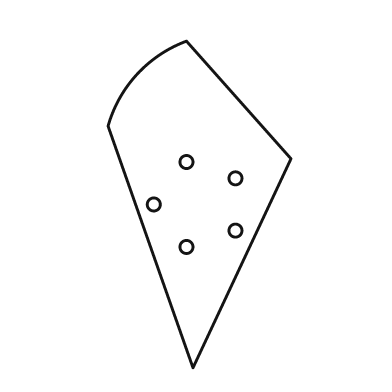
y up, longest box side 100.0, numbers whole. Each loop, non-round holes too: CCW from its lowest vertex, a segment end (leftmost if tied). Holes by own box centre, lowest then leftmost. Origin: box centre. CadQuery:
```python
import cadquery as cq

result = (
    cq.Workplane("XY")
    .moveTo(-2.0, -50.0)
    .lineTo(28.0, 14.0)
    .lineTo(-4.0, 50.0)
    .threePointArc((-19.0, 40.0), (-28.0, 24.0))
    .close()
    .moveTo(-4.0, -13.0)
    .circle(2.0)
    .moveTo(11.0, -8.0)
    .circle(2.0)
    .moveTo(-14.0, 0.0)
    .circle(2.0)
    .moveTo(11.0, 8.0)
    .circle(2.0)
    .moveTo(-4.0, 13.0)
    .circle(2.0)
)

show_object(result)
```